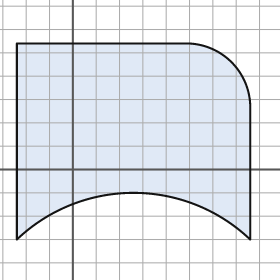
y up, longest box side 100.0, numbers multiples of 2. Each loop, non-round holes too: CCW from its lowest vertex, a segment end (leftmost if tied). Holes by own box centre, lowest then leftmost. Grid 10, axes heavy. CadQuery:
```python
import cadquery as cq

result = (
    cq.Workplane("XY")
    .moveTo(-24.0, -30.0)
    .threePointArc((26.0, -10.0), (76.0, -30.0))
    .lineTo(76.0, 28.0)
    .threePointArc((68.0, 46.0), (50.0, 54.0))
    .lineTo(-24.0, 54.0)
    .close()
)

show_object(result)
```